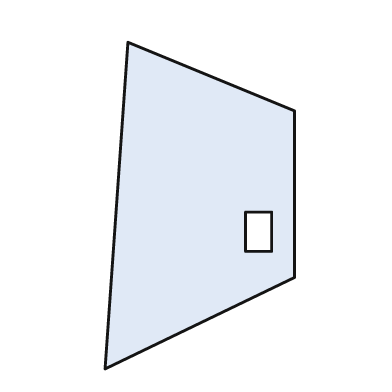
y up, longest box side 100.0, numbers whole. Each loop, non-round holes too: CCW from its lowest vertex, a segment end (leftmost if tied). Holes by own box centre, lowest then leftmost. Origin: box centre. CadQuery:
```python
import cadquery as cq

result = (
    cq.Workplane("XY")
    .moveTo(-29.0, -50.0)
    .lineTo(29.0, -22.0)
    .lineTo(29.0, 29.0)
    .lineTo(-22.0, 50.0)
    .close()
    .moveTo(14.0, -14.0)
    .lineTo(22.0, -14.0)
    .lineTo(22.0, -2.0)
    .lineTo(14.0, -2.0)
    .close()
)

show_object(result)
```